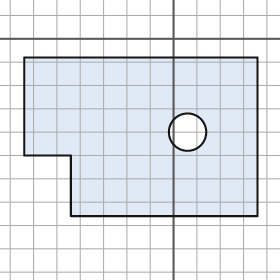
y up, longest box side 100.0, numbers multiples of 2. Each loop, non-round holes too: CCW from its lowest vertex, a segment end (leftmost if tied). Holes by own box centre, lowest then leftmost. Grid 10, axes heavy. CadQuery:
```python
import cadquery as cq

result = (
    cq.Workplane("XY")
    .moveTo(-44.0, -76.0)
    .lineTo(36.0, -76.0)
    .lineTo(36.0, -8.0)
    .lineTo(-64.0, -8.0)
    .lineTo(-64.0, -50.0)
    .lineTo(-44.0, -50.0)
    .close()
    .moveTo(6.0, -40.0)
    .circle(8.0)
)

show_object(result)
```